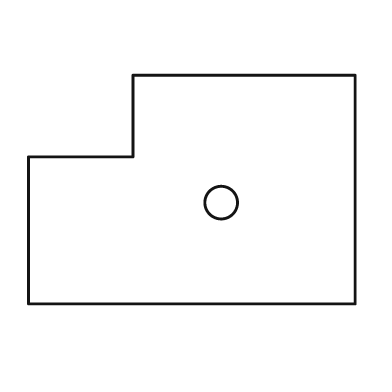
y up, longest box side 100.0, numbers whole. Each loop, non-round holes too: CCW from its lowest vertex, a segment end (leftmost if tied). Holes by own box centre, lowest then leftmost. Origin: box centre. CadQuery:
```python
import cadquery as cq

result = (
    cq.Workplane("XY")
    .moveTo(-50.0, -35.0)
    .lineTo(50.0, -35.0)
    .lineTo(50.0, 35.0)
    .lineTo(-18.0, 35.0)
    .lineTo(-18.0, 10.0)
    .lineTo(-50.0, 10.0)
    .close()
    .moveTo(9.0, -4.0)
    .circle(5.0)
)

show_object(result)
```